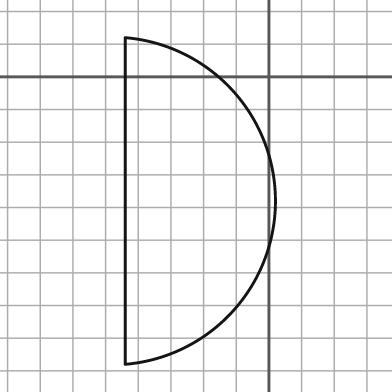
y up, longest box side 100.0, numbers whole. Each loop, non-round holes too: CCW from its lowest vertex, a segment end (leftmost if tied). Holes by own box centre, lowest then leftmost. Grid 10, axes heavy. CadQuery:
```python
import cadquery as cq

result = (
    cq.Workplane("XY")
    .moveTo(-44.0, -88.0)
    .threePointArc((2.0, -38.0), (-44.0, 12.0))
    .close()
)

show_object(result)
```